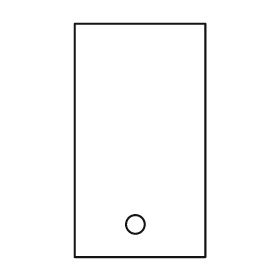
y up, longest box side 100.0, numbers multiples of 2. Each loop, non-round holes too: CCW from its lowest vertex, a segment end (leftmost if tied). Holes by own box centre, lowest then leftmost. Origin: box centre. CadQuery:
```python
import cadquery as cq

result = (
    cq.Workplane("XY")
    .moveTo(-28.0, -50.0)
    .lineTo(28.0, -50.0)
    .lineTo(28.0, 50.0)
    .lineTo(-28.0, 50.0)
    .close()
    .moveTo(-2.0, -36.0)
    .circle(4.0)
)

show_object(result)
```